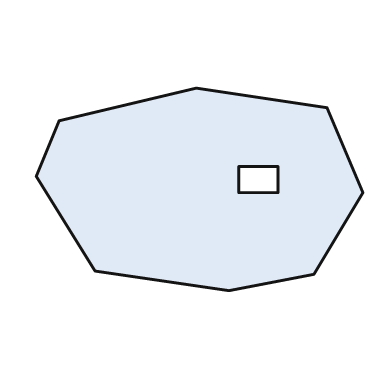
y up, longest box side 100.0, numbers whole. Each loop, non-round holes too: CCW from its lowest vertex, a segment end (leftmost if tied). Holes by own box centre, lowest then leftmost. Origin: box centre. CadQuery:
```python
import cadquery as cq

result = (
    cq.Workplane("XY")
    .moveTo(9.0, -31.0)
    .lineTo(35.0, -26.0)
    .lineTo(50.0, -1.0)
    .lineTo(39.0, 25.0)
    .lineTo(-1.0, 31.0)
    .lineTo(-43.0, 21.0)
    .lineTo(-50.0, 4.0)
    .lineTo(-32.0, -25.0)
    .close()
    .moveTo(12.0, -1.0)
    .lineTo(24.0, -1.0)
    .lineTo(24.0, 7.0)
    .lineTo(12.0, 7.0)
    .close()
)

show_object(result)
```